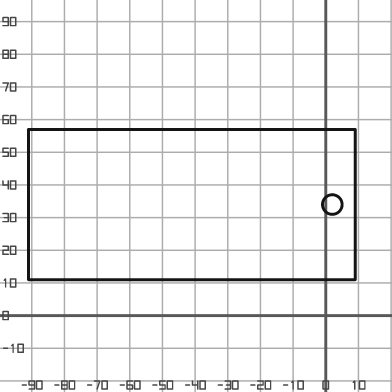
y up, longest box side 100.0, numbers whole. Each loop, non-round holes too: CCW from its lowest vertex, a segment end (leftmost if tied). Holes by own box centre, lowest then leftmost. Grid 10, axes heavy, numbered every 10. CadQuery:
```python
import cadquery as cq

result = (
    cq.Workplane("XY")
    .moveTo(-91.0, 11.0)
    .lineTo(9.0, 11.0)
    .lineTo(9.0, 57.0)
    .lineTo(-91.0, 57.0)
    .close()
    .moveTo(2.0, 34.0)
    .circle(3.0)
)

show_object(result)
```